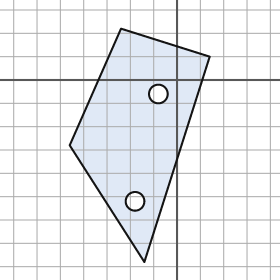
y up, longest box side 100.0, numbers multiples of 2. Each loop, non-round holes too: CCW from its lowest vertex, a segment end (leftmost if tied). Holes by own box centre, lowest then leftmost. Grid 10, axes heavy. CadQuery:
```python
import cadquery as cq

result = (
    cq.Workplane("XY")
    .moveTo(-14.0, -78.0)
    .lineTo(14.0, 10.0)
    .lineTo(-24.0, 22.0)
    .lineTo(-46.0, -28.0)
    .close()
    .moveTo(-18.0, -52.0)
    .circle(4.0)
    .moveTo(-8.0, -6.0)
    .circle(4.0)
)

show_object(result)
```